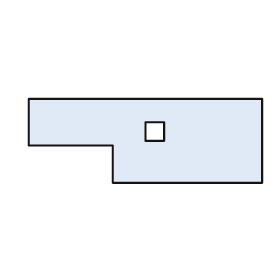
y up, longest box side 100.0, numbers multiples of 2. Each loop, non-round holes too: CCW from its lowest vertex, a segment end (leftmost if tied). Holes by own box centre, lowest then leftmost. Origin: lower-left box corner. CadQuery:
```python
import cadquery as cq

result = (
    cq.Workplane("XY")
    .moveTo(36.0, 0.0)
    .lineTo(100.0, 0.0)
    .lineTo(100.0, 36.0)
    .lineTo(0.0, 36.0)
    .lineTo(0.0, 16.0)
    .lineTo(36.0, 16.0)
    .close()
    .moveTo(50.0, 18.0)
    .lineTo(58.0, 18.0)
    .lineTo(58.0, 26.0)
    .lineTo(50.0, 26.0)
    .close()
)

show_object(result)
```